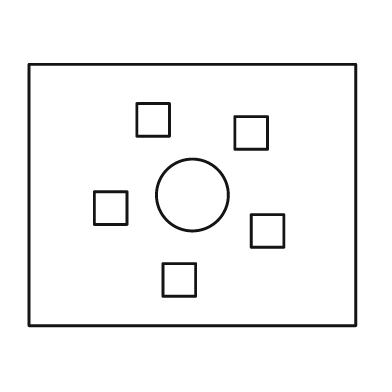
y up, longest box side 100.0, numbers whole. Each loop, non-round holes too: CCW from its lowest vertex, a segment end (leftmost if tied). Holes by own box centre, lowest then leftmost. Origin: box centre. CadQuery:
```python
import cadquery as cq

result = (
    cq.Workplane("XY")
    .moveTo(-50.0, -40.0)
    .lineTo(50.0, -40.0)
    .lineTo(50.0, 40.0)
    .lineTo(-50.0, 40.0)
    .close()
    .moveTo(-9.0, -31.0)
    .lineTo(1.0, -31.0)
    .lineTo(1.0, -21.0)
    .lineTo(-9.0, -21.0)
    .close()
    .moveTo(18.0, -16.0)
    .lineTo(28.0, -16.0)
    .lineTo(28.0, -6.0)
    .lineTo(18.0, -6.0)
    .close()
    .moveTo(-30.0, -9.0)
    .lineTo(-20.0, -9.0)
    .lineTo(-20.0, 1.0)
    .lineTo(-30.0, 1.0)
    .close()
    .moveTo(0.0, 0.0)
    .circle(11.0)
    .moveTo(13.0, 14.0)
    .lineTo(23.0, 14.0)
    .lineTo(23.0, 24.0)
    .lineTo(13.0, 24.0)
    .close()
    .moveTo(-17.0, 18.0)
    .lineTo(-7.0, 18.0)
    .lineTo(-7.0, 28.0)
    .lineTo(-17.0, 28.0)
    .close()
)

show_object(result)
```